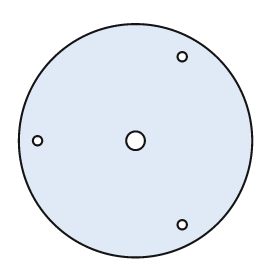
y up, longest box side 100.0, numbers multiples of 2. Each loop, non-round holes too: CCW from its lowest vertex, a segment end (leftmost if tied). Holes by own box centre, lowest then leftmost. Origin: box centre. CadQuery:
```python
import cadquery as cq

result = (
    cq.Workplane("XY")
    .moveTo(0.0, 0.0)
    .circle(50.0)
    .moveTo(20.0, -36.0)
    .circle(2.0)
    .moveTo(-42.0, 0.0)
    .circle(2.0)
    .moveTo(0.0, 0.0)
    .circle(4.0)
    .moveTo(20.0, 36.0)
    .circle(2.0)
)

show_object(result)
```